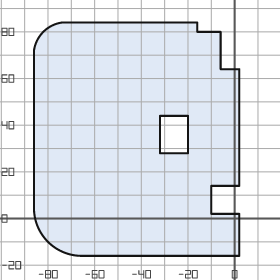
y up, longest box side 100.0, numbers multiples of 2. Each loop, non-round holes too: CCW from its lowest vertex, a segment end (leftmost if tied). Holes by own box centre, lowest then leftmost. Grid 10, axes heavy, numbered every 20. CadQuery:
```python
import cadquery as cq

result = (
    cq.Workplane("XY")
    .moveTo(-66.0, -16.0)
    .lineTo(2.0, -16.0)
    .lineTo(2.0, 2.0)
    .lineTo(-10.0, 2.0)
    .lineTo(-10.0, 14.0)
    .lineTo(2.0, 14.0)
    .lineTo(2.0, 64.0)
    .lineTo(-6.0, 64.0)
    .lineTo(-6.0, 80.0)
    .lineTo(-16.0, 80.0)
    .lineTo(-16.0, 84.0)
    .lineTo(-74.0, 84.0)
    .threePointArc((-82.0, 80.0), (-86.0, 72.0))
    .lineTo(-86.0, 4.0)
    .threePointArc((-80.0, -10.0), (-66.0, -16.0))
    .close()
    .moveTo(-32.0, 28.0)
    .lineTo(-20.0, 28.0)
    .lineTo(-20.0, 44.0)
    .lineTo(-32.0, 44.0)
    .close()
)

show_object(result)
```